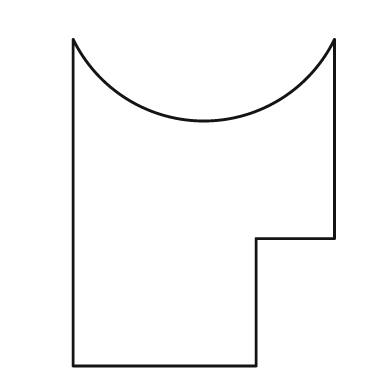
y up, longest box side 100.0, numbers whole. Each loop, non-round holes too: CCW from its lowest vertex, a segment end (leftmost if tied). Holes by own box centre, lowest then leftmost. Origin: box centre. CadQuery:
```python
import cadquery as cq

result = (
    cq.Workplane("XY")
    .moveTo(-40.0, -50.0)
    .lineTo(16.0, -50.0)
    .lineTo(16.0, -11.0)
    .lineTo(40.0, -11.0)
    .lineTo(40.0, 50.0)
    .threePointArc((0.0, 25.0), (-40.0, 50.0))
    .close()
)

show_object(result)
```